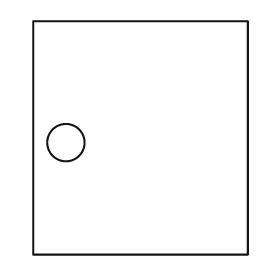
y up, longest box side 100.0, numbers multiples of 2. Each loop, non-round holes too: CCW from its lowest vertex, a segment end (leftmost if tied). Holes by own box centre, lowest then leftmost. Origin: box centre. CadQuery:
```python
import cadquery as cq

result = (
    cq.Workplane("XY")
    .moveTo(-46.0, -50.0)
    .lineTo(46.0, -50.0)
    .lineTo(46.0, 50.0)
    .lineTo(-46.0, 50.0)
    .close()
    .moveTo(-32.0, -2.0)
    .circle(8.0)
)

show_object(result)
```